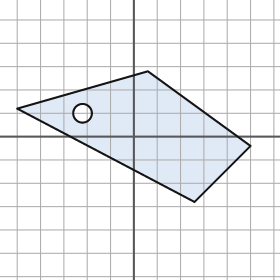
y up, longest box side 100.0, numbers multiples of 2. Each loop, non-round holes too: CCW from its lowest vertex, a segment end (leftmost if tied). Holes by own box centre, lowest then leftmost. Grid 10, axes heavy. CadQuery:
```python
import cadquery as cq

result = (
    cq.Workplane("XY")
    .moveTo(26.0, -28.0)
    .lineTo(50.0, -4.0)
    .lineTo(6.0, 28.0)
    .lineTo(-50.0, 12.0)
    .close()
    .moveTo(-22.0, 10.0)
    .circle(4.0)
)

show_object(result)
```